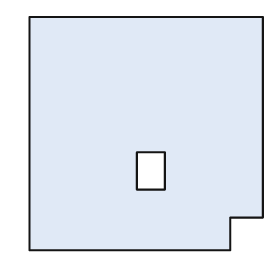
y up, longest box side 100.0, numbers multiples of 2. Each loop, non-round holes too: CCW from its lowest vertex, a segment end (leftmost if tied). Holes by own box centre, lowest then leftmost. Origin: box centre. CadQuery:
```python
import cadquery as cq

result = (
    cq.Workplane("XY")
    .moveTo(-50.0, -50.0)
    .lineTo(36.0, -50.0)
    .lineTo(36.0, -36.0)
    .lineTo(50.0, -36.0)
    .lineTo(50.0, 50.0)
    .lineTo(-50.0, 50.0)
    .close()
    .moveTo(-4.0, -24.0)
    .lineTo(8.0, -24.0)
    .lineTo(8.0, -8.0)
    .lineTo(-4.0, -8.0)
    .close()
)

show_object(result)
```